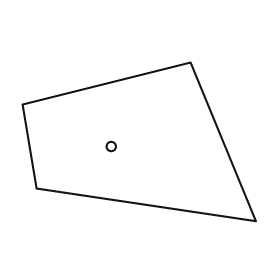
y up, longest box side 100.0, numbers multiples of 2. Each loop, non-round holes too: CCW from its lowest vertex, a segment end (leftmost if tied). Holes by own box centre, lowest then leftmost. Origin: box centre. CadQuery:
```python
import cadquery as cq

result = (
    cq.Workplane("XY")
    .moveTo(50.0, -34.0)
    .lineTo(22.0, 34.0)
    .lineTo(-50.0, 16.0)
    .lineTo(-44.0, -20.0)
    .close()
    .moveTo(-12.0, -2.0)
    .circle(2.0)
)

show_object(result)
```